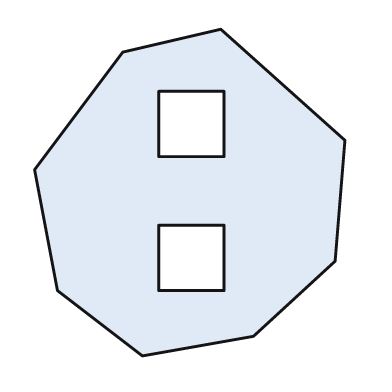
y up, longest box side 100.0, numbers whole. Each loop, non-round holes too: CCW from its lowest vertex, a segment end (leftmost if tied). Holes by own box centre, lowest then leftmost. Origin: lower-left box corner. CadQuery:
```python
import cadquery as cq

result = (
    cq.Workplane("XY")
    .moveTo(33.0, 0.0)
    .lineTo(67.0, 6.0)
    .lineTo(92.0, 29.0)
    .lineTo(95.0, 66.0)
    .lineTo(57.0, 100.0)
    .lineTo(27.0, 93.0)
    .lineTo(0.0, 57.0)
    .lineTo(7.0, 20.0)
    .close()
    .moveTo(38.0, 20.0)
    .lineTo(58.0, 20.0)
    .lineTo(58.0, 40.0)
    .lineTo(38.0, 40.0)
    .close()
    .moveTo(38.0, 61.0)
    .lineTo(58.0, 61.0)
    .lineTo(58.0, 81.0)
    .lineTo(38.0, 81.0)
    .close()
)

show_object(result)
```